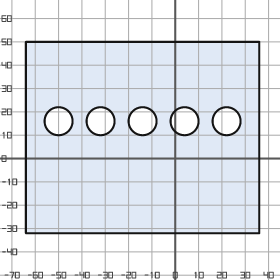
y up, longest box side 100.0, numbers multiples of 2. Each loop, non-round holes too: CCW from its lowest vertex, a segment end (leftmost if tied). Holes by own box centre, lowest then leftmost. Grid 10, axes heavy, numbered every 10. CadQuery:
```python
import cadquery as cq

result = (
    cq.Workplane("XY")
    .moveTo(-64.0, -32.0)
    .lineTo(36.0, -32.0)
    .lineTo(36.0, 50.0)
    .lineTo(-64.0, 50.0)
    .close()
    .moveTo(-50.0, 16.0)
    .circle(6.0)
    .moveTo(-32.0, 16.0)
    .circle(6.0)
    .moveTo(-14.0, 16.0)
    .circle(6.0)
    .moveTo(4.0, 16.0)
    .circle(6.0)
    .moveTo(22.0, 16.0)
    .circle(6.0)
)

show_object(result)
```